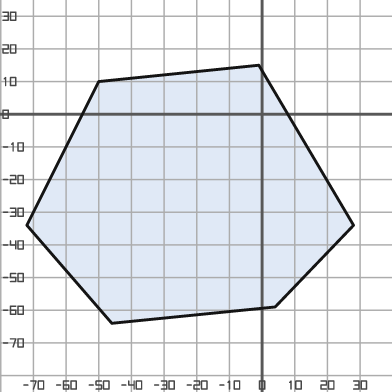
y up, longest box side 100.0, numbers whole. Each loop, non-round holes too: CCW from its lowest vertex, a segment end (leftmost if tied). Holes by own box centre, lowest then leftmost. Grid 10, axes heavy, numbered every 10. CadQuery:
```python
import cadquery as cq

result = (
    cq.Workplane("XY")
    .moveTo(-46.0, -64.0)
    .lineTo(4.0, -59.0)
    .lineTo(28.0, -34.0)
    .lineTo(-1.0, 15.0)
    .lineTo(-50.0, 10.0)
    .lineTo(-72.0, -34.0)
    .close()
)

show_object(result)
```